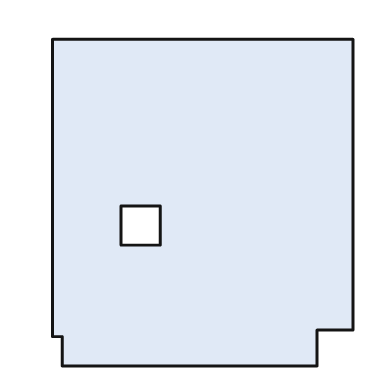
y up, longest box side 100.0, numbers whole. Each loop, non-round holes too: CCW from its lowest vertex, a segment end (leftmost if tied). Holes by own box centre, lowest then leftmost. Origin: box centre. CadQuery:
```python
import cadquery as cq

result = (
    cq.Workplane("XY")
    .moveTo(-43.0, -50.0)
    .lineTo(35.0, -50.0)
    .lineTo(35.0, -39.0)
    .lineTo(46.0, -39.0)
    .lineTo(46.0, 50.0)
    .lineTo(-46.0, 50.0)
    .lineTo(-46.0, -41.0)
    .lineTo(-43.0, -41.0)
    .close()
    .moveTo(-25.0, -13.0)
    .lineTo(-13.0, -13.0)
    .lineTo(-13.0, -1.0)
    .lineTo(-25.0, -1.0)
    .close()
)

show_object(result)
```